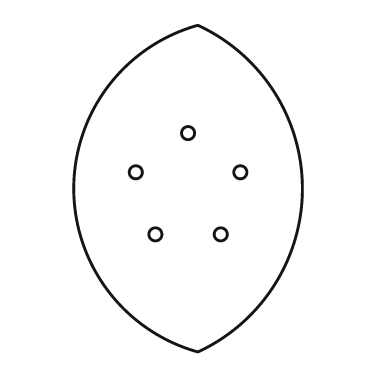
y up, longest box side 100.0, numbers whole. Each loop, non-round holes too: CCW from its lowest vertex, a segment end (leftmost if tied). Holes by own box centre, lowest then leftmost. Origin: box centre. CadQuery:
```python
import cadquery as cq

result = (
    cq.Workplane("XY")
    .moveTo(3.0, -50.0)
    .threePointArc((35.0, 0.0), (3.0, 50.0))
    .threePointArc((-35.0, 0.0), (3.0, -50.0))
    .close()
    .moveTo(-10.0, -14.0)
    .circle(2.0)
    .moveTo(10.0, -14.0)
    .circle(2.0)
    .moveTo(-16.0, 5.0)
    .circle(2.0)
    .moveTo(16.0, 5.0)
    .circle(2.0)
    .moveTo(0.0, 17.0)
    .circle(2.0)
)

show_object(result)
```